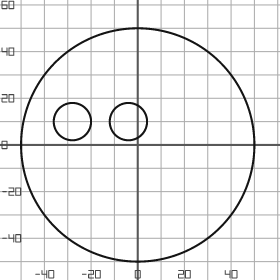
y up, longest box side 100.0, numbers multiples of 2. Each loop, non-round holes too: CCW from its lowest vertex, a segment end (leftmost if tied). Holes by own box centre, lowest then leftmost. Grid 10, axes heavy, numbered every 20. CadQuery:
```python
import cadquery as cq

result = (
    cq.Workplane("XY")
    .moveTo(0.0, 0.0)
    .circle(50.0)
    .moveTo(-28.0, 10.0)
    .circle(8.0)
    .moveTo(-4.0, 10.0)
    .circle(8.0)
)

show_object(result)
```